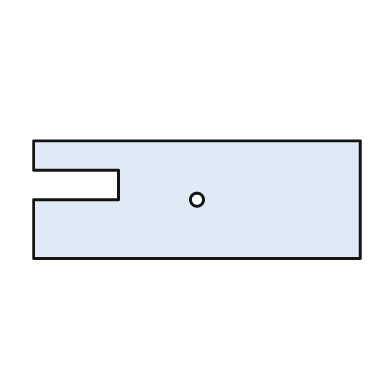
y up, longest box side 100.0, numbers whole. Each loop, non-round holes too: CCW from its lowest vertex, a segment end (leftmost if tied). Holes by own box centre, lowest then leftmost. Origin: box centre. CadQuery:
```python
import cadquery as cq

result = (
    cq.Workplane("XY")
    .moveTo(-50.0, -18.0)
    .lineTo(50.0, -18.0)
    .lineTo(50.0, 18.0)
    .lineTo(-50.0, 18.0)
    .lineTo(-50.0, 9.0)
    .lineTo(-24.0, 9.0)
    .lineTo(-24.0, 0.0)
    .lineTo(-50.0, 0.0)
    .close()
    .moveTo(0.0, 0.0)
    .circle(2.0)
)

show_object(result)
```